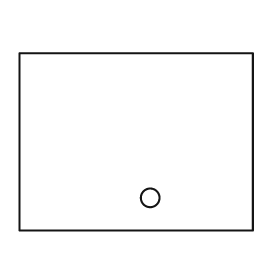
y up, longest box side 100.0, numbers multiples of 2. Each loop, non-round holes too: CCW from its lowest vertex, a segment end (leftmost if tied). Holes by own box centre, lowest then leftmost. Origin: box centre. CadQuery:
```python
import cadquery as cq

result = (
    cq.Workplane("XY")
    .moveTo(-50.0, -38.0)
    .lineTo(50.0, -38.0)
    .lineTo(50.0, 38.0)
    .lineTo(-50.0, 38.0)
    .close()
    .moveTo(6.0, -24.0)
    .circle(4.0)
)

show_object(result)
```